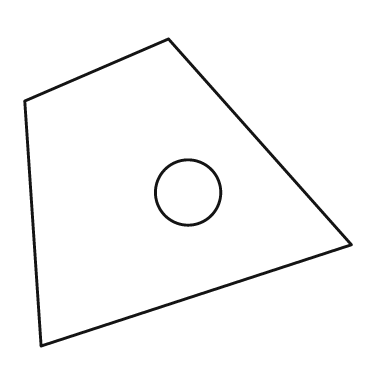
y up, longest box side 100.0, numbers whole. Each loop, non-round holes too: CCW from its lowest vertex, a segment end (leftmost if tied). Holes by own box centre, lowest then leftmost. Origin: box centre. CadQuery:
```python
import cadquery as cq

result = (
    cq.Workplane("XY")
    .moveTo(-45.0, -47.0)
    .lineTo(50.0, -16.0)
    .lineTo(-6.0, 47.0)
    .lineTo(-50.0, 28.0)
    .close()
    .moveTo(0.0, 0.0)
    .circle(10.0)
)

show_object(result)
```